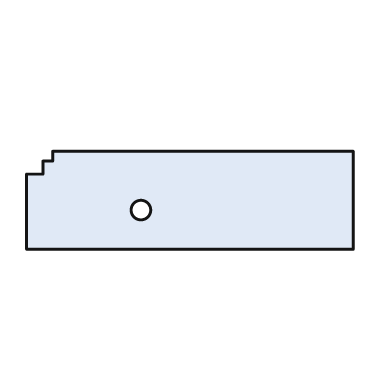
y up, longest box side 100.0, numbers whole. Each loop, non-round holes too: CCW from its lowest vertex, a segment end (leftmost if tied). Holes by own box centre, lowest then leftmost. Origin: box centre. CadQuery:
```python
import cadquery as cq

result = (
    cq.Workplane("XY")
    .moveTo(-50.0, -15.0)
    .lineTo(50.0, -15.0)
    .lineTo(50.0, 15.0)
    .lineTo(-42.0, 15.0)
    .lineTo(-42.0, 12.0)
    .lineTo(-45.0, 12.0)
    .lineTo(-45.0, 8.0)
    .lineTo(-50.0, 8.0)
    .close()
    .moveTo(-15.0, -3.0)
    .circle(3.0)
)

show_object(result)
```